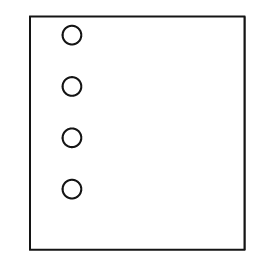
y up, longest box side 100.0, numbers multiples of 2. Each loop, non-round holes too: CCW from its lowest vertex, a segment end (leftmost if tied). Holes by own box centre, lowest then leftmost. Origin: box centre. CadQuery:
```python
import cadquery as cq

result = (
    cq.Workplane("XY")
    .moveTo(-46.0, -50.0)
    .lineTo(46.0, -50.0)
    .lineTo(46.0, 50.0)
    .lineTo(-46.0, 50.0)
    .close()
    .moveTo(-28.0, -24.0)
    .circle(4.0)
    .moveTo(-28.0, -2.0)
    .circle(4.0)
    .moveTo(-28.0, 20.0)
    .circle(4.0)
    .moveTo(-28.0, 42.0)
    .circle(4.0)
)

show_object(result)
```